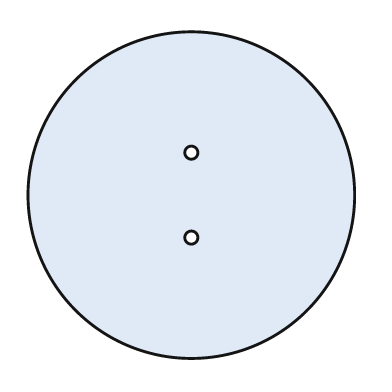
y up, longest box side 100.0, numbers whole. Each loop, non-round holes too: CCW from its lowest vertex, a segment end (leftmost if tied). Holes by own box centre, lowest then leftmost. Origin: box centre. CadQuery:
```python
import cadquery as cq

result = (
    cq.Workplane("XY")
    .moveTo(0.0, 0.0)
    .circle(50.0)
    .moveTo(0.0, -13.0)
    .circle(2.0)
    .moveTo(0.0, 13.0)
    .circle(2.0)
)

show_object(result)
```